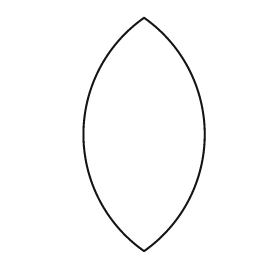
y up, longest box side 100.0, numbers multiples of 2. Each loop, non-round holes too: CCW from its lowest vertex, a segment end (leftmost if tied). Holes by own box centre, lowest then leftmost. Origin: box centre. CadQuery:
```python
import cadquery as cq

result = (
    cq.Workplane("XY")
    .moveTo(0.0, -50.0)
    .threePointArc((26.0, 0.0), (0.0, 50.0))
    .threePointArc((-26.0, 0.0), (0.0, -50.0))
    .close()
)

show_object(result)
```